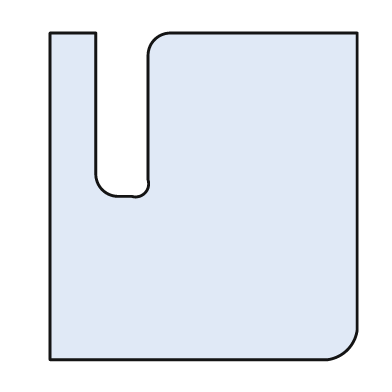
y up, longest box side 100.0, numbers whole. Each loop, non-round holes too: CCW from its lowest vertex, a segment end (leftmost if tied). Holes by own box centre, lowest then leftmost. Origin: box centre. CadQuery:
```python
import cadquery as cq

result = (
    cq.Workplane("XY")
    .moveTo(-47.0, -50.0)
    .lineTo(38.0, -50.0)
    .threePointArc((44.0, -47.0), (47.0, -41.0))
    .lineTo(47.0, 50.0)
    .lineTo(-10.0, 50.0)
    .threePointArc((-15.0, 48.0), (-17.0, 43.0))
    .lineTo(-17.0, 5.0)
    .threePointArc((-18.0, 1.0), (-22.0, 0.0))
    .lineTo(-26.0, 0.0)
    .threePointArc((-31.0, 2.0), (-33.0, 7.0))
    .lineTo(-33.0, 50.0)
    .lineTo(-47.0, 50.0)
    .close()
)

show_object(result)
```